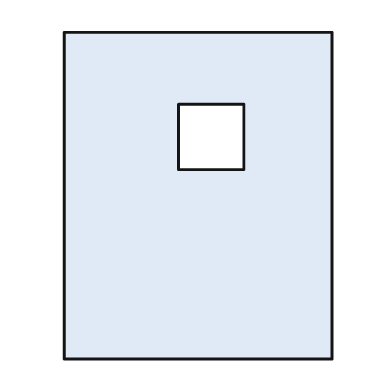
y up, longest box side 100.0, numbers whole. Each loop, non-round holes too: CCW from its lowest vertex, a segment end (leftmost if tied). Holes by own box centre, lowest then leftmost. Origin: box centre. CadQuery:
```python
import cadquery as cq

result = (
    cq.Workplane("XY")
    .moveTo(-41.0, -50.0)
    .lineTo(41.0, -50.0)
    .lineTo(41.0, 50.0)
    .lineTo(-41.0, 50.0)
    .close()
    .moveTo(-6.0, 8.0)
    .lineTo(14.0, 8.0)
    .lineTo(14.0, 28.0)
    .lineTo(-6.0, 28.0)
    .close()
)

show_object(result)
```